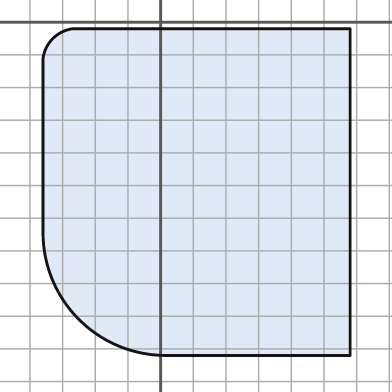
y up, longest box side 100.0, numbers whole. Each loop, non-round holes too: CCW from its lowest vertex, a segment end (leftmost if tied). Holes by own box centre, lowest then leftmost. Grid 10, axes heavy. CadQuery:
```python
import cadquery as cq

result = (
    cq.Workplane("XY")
    .moveTo(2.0, -102.0)
    .lineTo(58.0, -102.0)
    .lineTo(58.0, -2.0)
    .lineTo(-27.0, -2.0)
    .threePointArc((-33.0, -5.0), (-36.0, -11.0))
    .lineTo(-36.0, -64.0)
    .threePointArc((-25.0, -91.0), (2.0, -102.0))
    .close()
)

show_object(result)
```